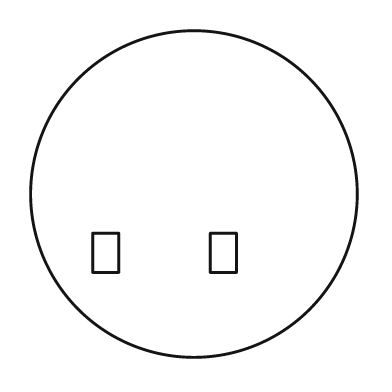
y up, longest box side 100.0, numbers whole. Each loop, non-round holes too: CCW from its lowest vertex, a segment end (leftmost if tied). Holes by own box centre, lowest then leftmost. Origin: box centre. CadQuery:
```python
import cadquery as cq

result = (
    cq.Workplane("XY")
    .moveTo(0.0, 0.0)
    .circle(50.0)
    .moveTo(-31.0, -24.0)
    .lineTo(-23.0, -24.0)
    .lineTo(-23.0, -12.0)
    .lineTo(-31.0, -12.0)
    .close()
    .moveTo(5.0, -24.0)
    .lineTo(13.0, -24.0)
    .lineTo(13.0, -12.0)
    .lineTo(5.0, -12.0)
    .close()
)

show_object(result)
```